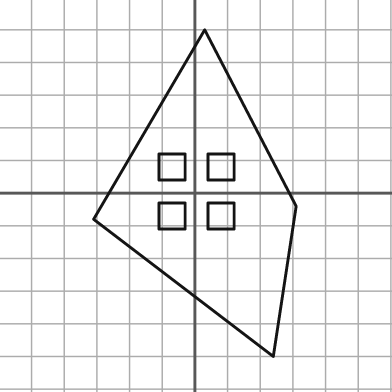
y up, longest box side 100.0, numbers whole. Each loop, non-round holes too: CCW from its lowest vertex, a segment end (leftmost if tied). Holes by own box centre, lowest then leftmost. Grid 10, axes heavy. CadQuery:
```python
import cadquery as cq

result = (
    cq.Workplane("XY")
    .moveTo(24.0, -50.0)
    .lineTo(31.0, -4.0)
    .lineTo(3.0, 50.0)
    .lineTo(-31.0, -8.0)
    .close()
    .moveTo(-11.0, -11.0)
    .lineTo(-3.0, -11.0)
    .lineTo(-3.0, -3.0)
    .lineTo(-11.0, -3.0)
    .close()
    .moveTo(4.0, -11.0)
    .lineTo(12.0, -11.0)
    .lineTo(12.0, -3.0)
    .lineTo(4.0, -3.0)
    .close()
    .moveTo(-11.0, 4.0)
    .lineTo(-3.0, 4.0)
    .lineTo(-3.0, 12.0)
    .lineTo(-11.0, 12.0)
    .close()
    .moveTo(4.0, 4.0)
    .lineTo(12.0, 4.0)
    .lineTo(12.0, 12.0)
    .lineTo(4.0, 12.0)
    .close()
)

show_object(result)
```